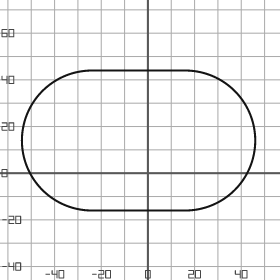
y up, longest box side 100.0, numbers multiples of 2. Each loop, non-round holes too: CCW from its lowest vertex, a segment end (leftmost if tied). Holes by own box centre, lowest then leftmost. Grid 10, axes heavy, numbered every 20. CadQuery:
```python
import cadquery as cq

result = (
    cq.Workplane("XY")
    .moveTo(-24.0, -16.0)
    .lineTo(16.0, -16.0)
    .threePointArc((46.0, 14.0), (16.0, 44.0))
    .lineTo(-24.0, 44.0)
    .threePointArc((-54.0, 14.0), (-24.0, -16.0))
    .close()
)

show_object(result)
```